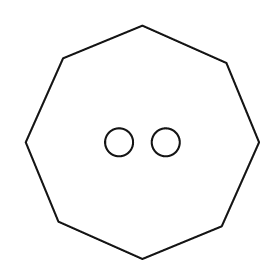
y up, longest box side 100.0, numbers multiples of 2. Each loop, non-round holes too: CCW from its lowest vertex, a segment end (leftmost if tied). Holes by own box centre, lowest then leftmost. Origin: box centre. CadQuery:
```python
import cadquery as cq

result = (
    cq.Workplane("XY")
    .moveTo(0.0, -50.0)
    .lineTo(34.0, -36.0)
    .lineTo(50.0, 0.0)
    .lineTo(36.0, 34.0)
    .lineTo(0.0, 50.0)
    .lineTo(-34.0, 36.0)
    .lineTo(-50.0, 0.0)
    .lineTo(-36.0, -34.0)
    .close()
    .moveTo(-10.0, 0.0)
    .circle(6.0)
    .moveTo(10.0, 0.0)
    .circle(6.0)
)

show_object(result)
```